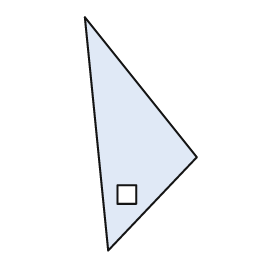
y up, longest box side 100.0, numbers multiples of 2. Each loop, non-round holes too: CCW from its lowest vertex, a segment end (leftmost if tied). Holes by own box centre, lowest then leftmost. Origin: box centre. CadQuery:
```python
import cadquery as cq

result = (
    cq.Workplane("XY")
    .moveTo(-14.0, -50.0)
    .lineTo(24.0, -10.0)
    .lineTo(-24.0, 50.0)
    .close()
    .moveTo(-10.0, -30.0)
    .lineTo(-2.0, -30.0)
    .lineTo(-2.0, -22.0)
    .lineTo(-10.0, -22.0)
    .close()
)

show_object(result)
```